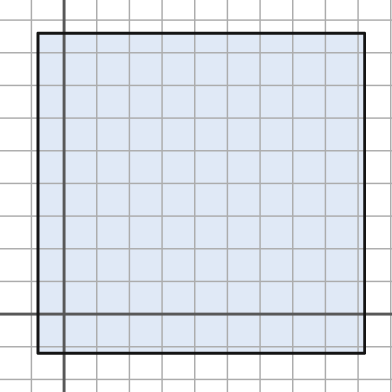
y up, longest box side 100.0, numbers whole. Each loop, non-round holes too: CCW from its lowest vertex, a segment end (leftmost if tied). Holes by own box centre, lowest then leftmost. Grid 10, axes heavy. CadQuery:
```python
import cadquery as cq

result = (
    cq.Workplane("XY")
    .moveTo(-8.0, -12.0)
    .lineTo(92.0, -12.0)
    .lineTo(92.0, 86.0)
    .lineTo(-8.0, 86.0)
    .close()
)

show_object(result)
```